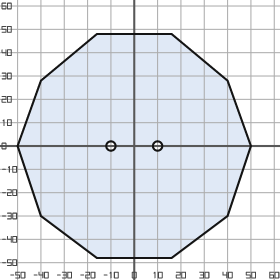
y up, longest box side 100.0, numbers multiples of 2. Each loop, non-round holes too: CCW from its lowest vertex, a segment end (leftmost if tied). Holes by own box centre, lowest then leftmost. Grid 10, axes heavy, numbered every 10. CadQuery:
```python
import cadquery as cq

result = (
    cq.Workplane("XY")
    .moveTo(-16.0, -48.0)
    .lineTo(16.0, -48.0)
    .lineTo(40.0, -30.0)
    .lineTo(50.0, 0.0)
    .lineTo(40.0, 28.0)
    .lineTo(16.0, 48.0)
    .lineTo(-16.0, 48.0)
    .lineTo(-40.0, 28.0)
    .lineTo(-50.0, 0.0)
    .lineTo(-40.0, -30.0)
    .close()
    .moveTo(-10.0, 0.0)
    .circle(2.0)
    .moveTo(10.0, 0.0)
    .circle(2.0)
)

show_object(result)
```